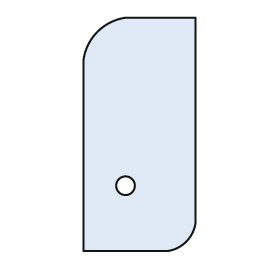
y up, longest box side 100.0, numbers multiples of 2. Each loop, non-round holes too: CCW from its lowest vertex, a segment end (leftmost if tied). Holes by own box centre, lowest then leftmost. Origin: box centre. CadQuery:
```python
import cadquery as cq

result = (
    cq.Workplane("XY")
    .moveTo(-24.0, -50.0)
    .lineTo(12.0, -50.0)
    .threePointArc((20.0, -46.0), (24.0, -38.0))
    .lineTo(24.0, 50.0)
    .lineTo(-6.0, 50.0)
    .threePointArc((-18.0, 44.0), (-24.0, 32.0))
    .close()
    .moveTo(-6.0, -22.0)
    .circle(4.0)
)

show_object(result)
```